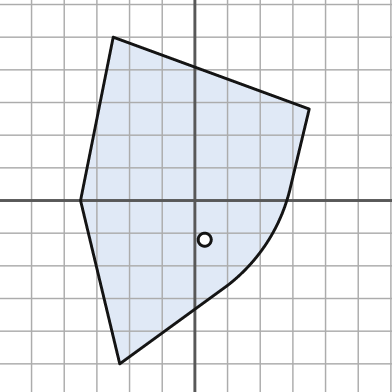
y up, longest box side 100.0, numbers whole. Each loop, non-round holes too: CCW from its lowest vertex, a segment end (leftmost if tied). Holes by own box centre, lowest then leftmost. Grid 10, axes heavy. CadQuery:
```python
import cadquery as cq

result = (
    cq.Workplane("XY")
    .moveTo(-23.0, -50.0)
    .lineTo(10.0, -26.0)
    .threePointArc((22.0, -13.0), (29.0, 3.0))
    .lineTo(35.0, 28.0)
    .lineTo(-25.0, 50.0)
    .lineTo(-35.0, 0.0)
    .close()
    .moveTo(3.0, -12.0)
    .circle(2.0)
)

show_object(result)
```